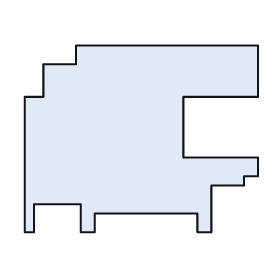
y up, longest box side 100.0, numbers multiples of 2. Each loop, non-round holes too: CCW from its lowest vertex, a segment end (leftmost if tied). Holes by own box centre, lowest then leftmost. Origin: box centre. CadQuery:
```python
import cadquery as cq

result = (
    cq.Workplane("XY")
    .moveTo(-50.0, -40.0)
    .lineTo(-46.0, -40.0)
    .lineTo(-46.0, -28.0)
    .lineTo(-26.0, -28.0)
    .lineTo(-26.0, -40.0)
    .lineTo(-20.0, -40.0)
    .lineTo(-20.0, -32.0)
    .lineTo(24.0, -32.0)
    .lineTo(24.0, -40.0)
    .lineTo(30.0, -40.0)
    .lineTo(30.0, -20.0)
    .lineTo(44.0, -20.0)
    .lineTo(44.0, -16.0)
    .lineTo(50.0, -16.0)
    .lineTo(50.0, -8.0)
    .lineTo(18.0, -8.0)
    .lineTo(18.0, 18.0)
    .lineTo(50.0, 18.0)
    .lineTo(50.0, 40.0)
    .lineTo(-28.0, 40.0)
    .lineTo(-28.0, 32.0)
    .lineTo(-42.0, 32.0)
    .lineTo(-42.0, 18.0)
    .lineTo(-50.0, 18.0)
    .close()
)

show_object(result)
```